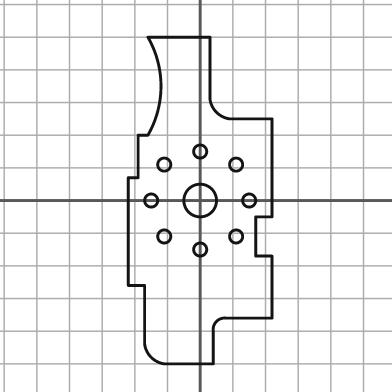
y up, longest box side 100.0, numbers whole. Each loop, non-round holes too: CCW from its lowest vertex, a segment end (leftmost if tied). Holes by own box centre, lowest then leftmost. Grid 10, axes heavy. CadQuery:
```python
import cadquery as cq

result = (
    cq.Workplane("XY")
    .moveTo(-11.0, -50.0)
    .lineTo(4.0, -50.0)
    .lineTo(4.0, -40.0)
    .threePointArc((5.0, -37.0), (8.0, -36.0))
    .lineTo(22.0, -36.0)
    .lineTo(22.0, -17.0)
    .lineTo(17.0, -17.0)
    .lineTo(17.0, -5.0)
    .lineTo(22.0, -5.0)
    .lineTo(22.0, 25.0)
    .lineTo(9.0, 25.0)
    .threePointArc((5.0, 27.0), (3.0, 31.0))
    .lineTo(3.0, 50.0)
    .lineTo(-16.0, 50.0)
    .threePointArc((-12.0, 35.0), (-16.0, 20.0))
    .lineTo(-19.0, 20.0)
    .lineTo(-19.0, 7.0)
    .lineTo(-22.0, 7.0)
    .lineTo(-22.0, -26.0)
    .lineTo(-17.0, -26.0)
    .lineTo(-17.0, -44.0)
    .threePointArc((-15.0, -48.0), (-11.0, -50.0))
    .close()
    .moveTo(0.0, -15.0)
    .circle(2.0)
    .moveTo(-11.0, -11.0)
    .circle(2.0)
    .moveTo(11.0, -11.0)
    .circle(2.0)
    .moveTo(-15.0, 0.0)
    .circle(2.0)
    .moveTo(0.0, 0.0)
    .circle(5.0)
    .moveTo(15.0, 0.0)
    .circle(2.0)
    .moveTo(-11.0, 11.0)
    .circle(2.0)
    .moveTo(11.0, 11.0)
    .circle(2.0)
    .moveTo(0.0, 15.0)
    .circle(2.0)
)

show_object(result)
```